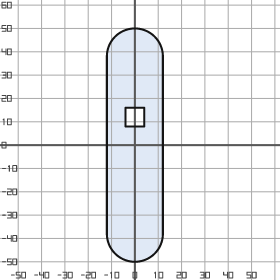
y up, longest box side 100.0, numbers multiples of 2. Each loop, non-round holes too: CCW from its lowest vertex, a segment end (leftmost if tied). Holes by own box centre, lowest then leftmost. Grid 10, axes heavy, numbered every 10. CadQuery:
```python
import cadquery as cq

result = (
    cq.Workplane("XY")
    .moveTo(-12.0, -38.0)
    .threePointArc((0.0, -50.0), (12.0, -38.0))
    .lineTo(12.0, 38.0)
    .threePointArc((0.0, 50.0), (-12.0, 38.0))
    .close()
    .moveTo(-4.0, 8.0)
    .lineTo(4.0, 8.0)
    .lineTo(4.0, 16.0)
    .lineTo(-4.0, 16.0)
    .close()
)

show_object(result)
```